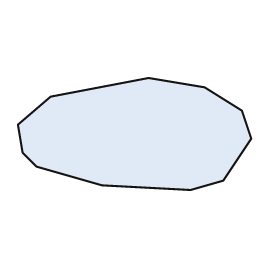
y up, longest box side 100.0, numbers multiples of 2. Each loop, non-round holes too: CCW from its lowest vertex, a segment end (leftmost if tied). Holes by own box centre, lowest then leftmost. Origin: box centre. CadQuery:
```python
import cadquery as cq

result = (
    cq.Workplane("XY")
    .moveTo(24.0, -24.0)
    .lineTo(38.0, -20.0)
    .lineTo(50.0, -2.0)
    .lineTo(46.0, 10.0)
    .lineTo(30.0, 20.0)
    .lineTo(6.0, 24.0)
    .lineTo(-36.0, 16.0)
    .lineTo(-50.0, 4.0)
    .lineTo(-48.0, -8.0)
    .lineTo(-42.0, -14.0)
    .lineTo(-14.0, -22.0)
    .close()
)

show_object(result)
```